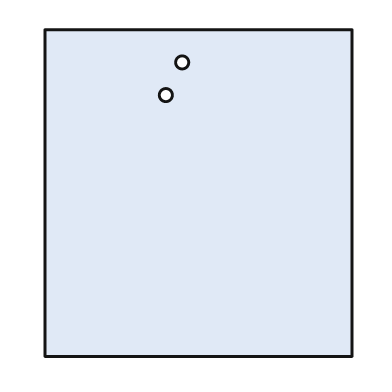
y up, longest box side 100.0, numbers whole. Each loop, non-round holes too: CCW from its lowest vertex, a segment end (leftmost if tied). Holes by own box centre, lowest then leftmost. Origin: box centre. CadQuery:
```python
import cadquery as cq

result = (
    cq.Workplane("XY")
    .moveTo(-47.0, -50.0)
    .lineTo(47.0, -50.0)
    .lineTo(47.0, 50.0)
    .lineTo(-47.0, 50.0)
    .close()
    .moveTo(-10.0, 30.0)
    .circle(2.0)
    .moveTo(-5.0, 40.0)
    .circle(2.0)
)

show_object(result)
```